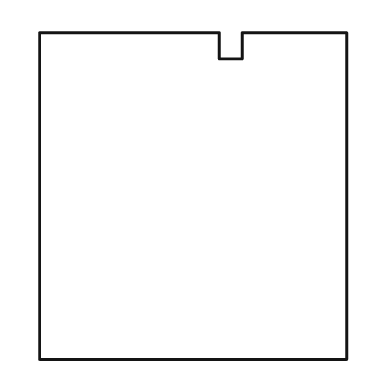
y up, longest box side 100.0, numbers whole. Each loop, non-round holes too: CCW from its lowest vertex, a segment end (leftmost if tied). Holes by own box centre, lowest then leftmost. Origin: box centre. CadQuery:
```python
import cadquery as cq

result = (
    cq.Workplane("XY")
    .moveTo(-47.0, -50.0)
    .lineTo(47.0, -50.0)
    .lineTo(47.0, 50.0)
    .lineTo(15.0, 50.0)
    .lineTo(15.0, 42.0)
    .lineTo(8.0, 42.0)
    .lineTo(8.0, 50.0)
    .lineTo(-47.0, 50.0)
    .close()
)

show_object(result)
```